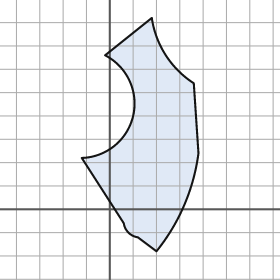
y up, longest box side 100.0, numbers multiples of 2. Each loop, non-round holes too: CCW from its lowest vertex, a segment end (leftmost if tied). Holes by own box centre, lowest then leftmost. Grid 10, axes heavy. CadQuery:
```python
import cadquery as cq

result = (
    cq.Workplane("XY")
    .moveTo(20.0, -18.0)
    .threePointArc((32.0, 2.0), (38.0, 24.0))
    .lineTo(36.0, 54.0)
    .threePointArc((24.0, 66.0), (18.0, 82.0))
    .lineTo(-2.0, 66.0)
    .threePointArc((10.0, 40.0), (-12.0, 22.0))
    .lineTo(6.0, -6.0)
    .threePointArc((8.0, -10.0), (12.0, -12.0))
    .close()
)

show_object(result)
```